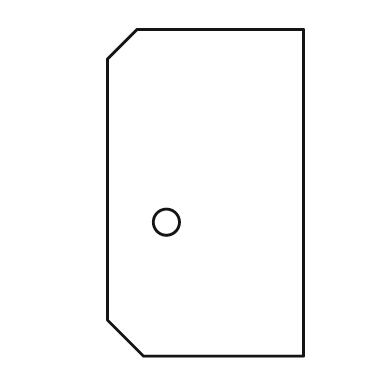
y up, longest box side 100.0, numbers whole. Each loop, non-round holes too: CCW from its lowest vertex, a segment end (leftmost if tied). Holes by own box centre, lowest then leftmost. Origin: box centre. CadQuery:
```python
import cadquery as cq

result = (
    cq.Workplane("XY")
    .moveTo(-19.0, -50.0)
    .lineTo(30.0, -50.0)
    .lineTo(30.0, 50.0)
    .lineTo(-21.0, 50.0)
    .lineTo(-30.0, 41.0)
    .lineTo(-30.0, -39.0)
    .close()
    .moveTo(-12.0, -9.0)
    .circle(4.0)
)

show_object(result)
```